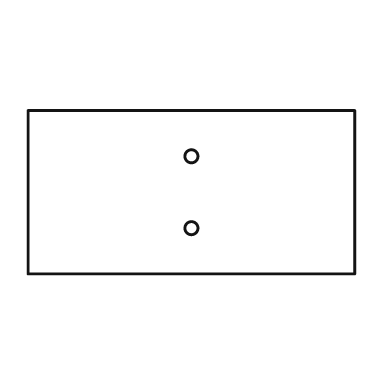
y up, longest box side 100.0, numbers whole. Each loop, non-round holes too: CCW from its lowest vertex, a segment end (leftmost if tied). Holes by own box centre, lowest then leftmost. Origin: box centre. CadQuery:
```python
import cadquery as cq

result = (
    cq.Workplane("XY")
    .moveTo(-50.0, -25.0)
    .lineTo(50.0, -25.0)
    .lineTo(50.0, 25.0)
    .lineTo(-50.0, 25.0)
    .close()
    .moveTo(0.0, -11.0)
    .circle(2.0)
    .moveTo(0.0, 11.0)
    .circle(2.0)
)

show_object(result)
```